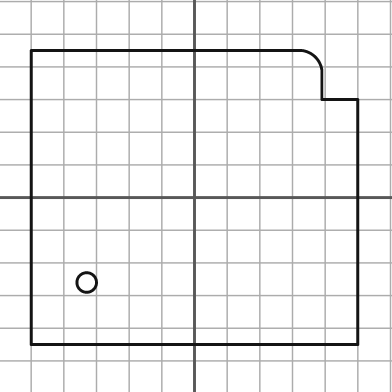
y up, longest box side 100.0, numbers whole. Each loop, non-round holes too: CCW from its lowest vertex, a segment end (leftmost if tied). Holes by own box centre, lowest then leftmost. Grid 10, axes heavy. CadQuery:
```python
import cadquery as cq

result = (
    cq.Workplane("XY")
    .moveTo(-50.0, -45.0)
    .lineTo(50.0, -45.0)
    .lineTo(50.0, 30.0)
    .lineTo(39.0, 30.0)
    .lineTo(39.0, 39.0)
    .threePointArc((37.0, 43.0), (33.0, 45.0))
    .lineTo(-50.0, 45.0)
    .close()
    .moveTo(-33.0, -26.0)
    .circle(3.0)
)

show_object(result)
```